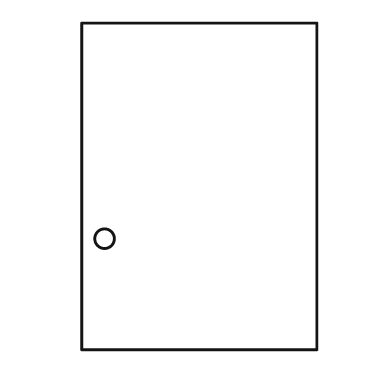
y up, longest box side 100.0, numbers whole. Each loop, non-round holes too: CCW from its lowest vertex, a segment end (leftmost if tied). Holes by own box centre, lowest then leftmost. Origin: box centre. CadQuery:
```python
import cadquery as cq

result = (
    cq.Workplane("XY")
    .moveTo(-36.0, -50.0)
    .lineTo(36.0, -50.0)
    .lineTo(36.0, 50.0)
    .lineTo(-36.0, 50.0)
    .close()
    .moveTo(-29.0, -16.0)
    .circle(3.0)
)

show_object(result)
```